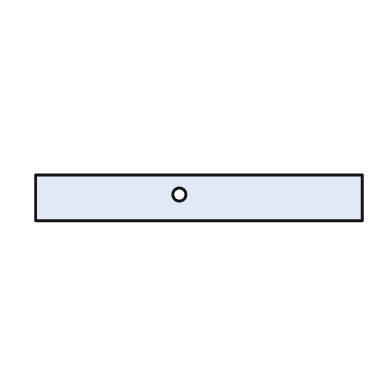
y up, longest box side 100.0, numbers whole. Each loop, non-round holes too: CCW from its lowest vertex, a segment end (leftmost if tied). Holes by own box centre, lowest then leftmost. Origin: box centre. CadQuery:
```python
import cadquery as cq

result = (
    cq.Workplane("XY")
    .moveTo(-50.0, -7.0)
    .lineTo(50.0, -7.0)
    .lineTo(50.0, 7.0)
    .lineTo(-50.0, 7.0)
    .close()
    .moveTo(-6.0, 1.0)
    .circle(2.0)
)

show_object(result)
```